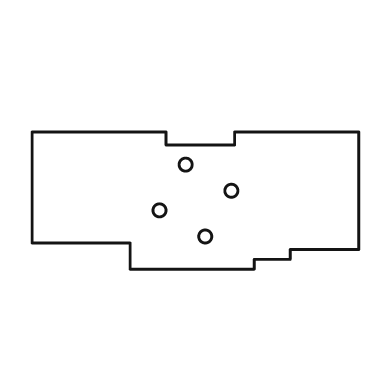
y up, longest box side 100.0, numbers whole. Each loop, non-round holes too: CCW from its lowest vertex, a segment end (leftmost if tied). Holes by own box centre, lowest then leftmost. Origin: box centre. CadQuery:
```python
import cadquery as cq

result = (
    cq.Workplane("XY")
    .moveTo(-20.0, -21.0)
    .lineTo(18.0, -21.0)
    .lineTo(18.0, -18.0)
    .lineTo(29.0, -18.0)
    .lineTo(29.0, -15.0)
    .lineTo(50.0, -15.0)
    .lineTo(50.0, 21.0)
    .lineTo(12.0, 21.0)
    .lineTo(12.0, 17.0)
    .lineTo(-9.0, 17.0)
    .lineTo(-9.0, 21.0)
    .lineTo(-50.0, 21.0)
    .lineTo(-50.0, -13.0)
    .lineTo(-20.0, -13.0)
    .close()
    .moveTo(3.0, -11.0)
    .circle(2.0)
    .moveTo(-11.0, -3.0)
    .circle(2.0)
    .moveTo(11.0, 3.0)
    .circle(2.0)
    .moveTo(-3.0, 11.0)
    .circle(2.0)
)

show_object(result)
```